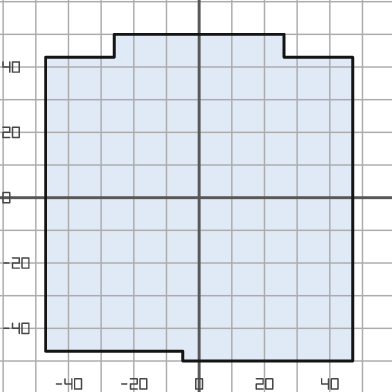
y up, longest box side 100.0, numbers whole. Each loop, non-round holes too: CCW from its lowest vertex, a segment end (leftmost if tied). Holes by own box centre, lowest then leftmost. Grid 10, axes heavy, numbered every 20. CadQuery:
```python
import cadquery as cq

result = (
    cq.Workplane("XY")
    .moveTo(-5.0, -50.0)
    .lineTo(47.0, -50.0)
    .lineTo(47.0, 43.0)
    .lineTo(26.0, 43.0)
    .lineTo(26.0, 50.0)
    .lineTo(-26.0, 50.0)
    .lineTo(-26.0, 43.0)
    .lineTo(-47.0, 43.0)
    .lineTo(-47.0, -47.0)
    .lineTo(-5.0, -47.0)
    .close()
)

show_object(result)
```